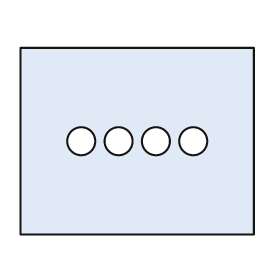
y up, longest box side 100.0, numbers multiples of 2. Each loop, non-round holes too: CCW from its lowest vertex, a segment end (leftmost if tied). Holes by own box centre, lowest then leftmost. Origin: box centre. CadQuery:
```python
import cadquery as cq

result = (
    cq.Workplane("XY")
    .moveTo(-50.0, -40.0)
    .lineTo(50.0, -40.0)
    .lineTo(50.0, 40.0)
    .lineTo(-50.0, 40.0)
    .close()
    .moveTo(-24.0, 0.0)
    .circle(6.0)
    .moveTo(-8.0, 0.0)
    .circle(6.0)
    .moveTo(8.0, 0.0)
    .circle(6.0)
    .moveTo(24.0, 0.0)
    .circle(6.0)
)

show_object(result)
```